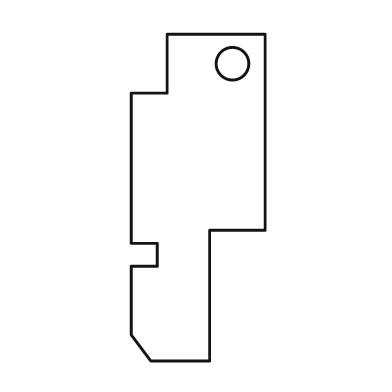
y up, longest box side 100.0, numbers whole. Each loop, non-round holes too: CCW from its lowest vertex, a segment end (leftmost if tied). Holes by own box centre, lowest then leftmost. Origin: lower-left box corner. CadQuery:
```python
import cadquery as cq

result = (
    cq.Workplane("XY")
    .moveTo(6.0, 0.0)
    .lineTo(24.0, 0.0)
    .lineTo(24.0, 40.0)
    .lineTo(41.0, 40.0)
    .lineTo(41.0, 100.0)
    .lineTo(11.0, 100.0)
    .lineTo(11.0, 82.0)
    .lineTo(0.0, 82.0)
    .lineTo(0.0, 36.0)
    .lineTo(8.0, 36.0)
    .lineTo(8.0, 29.0)
    .lineTo(0.0, 29.0)
    .lineTo(0.0, 8.0)
    .close()
    .moveTo(31.0, 91.0)
    .circle(5.0)
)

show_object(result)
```